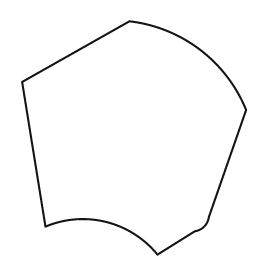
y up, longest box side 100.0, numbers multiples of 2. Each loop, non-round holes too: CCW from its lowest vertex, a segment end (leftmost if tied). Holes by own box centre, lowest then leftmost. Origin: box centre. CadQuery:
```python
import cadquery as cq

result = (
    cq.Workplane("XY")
    .moveTo(10.0, -50.0)
    .lineTo(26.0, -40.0)
    .threePointArc((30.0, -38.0), (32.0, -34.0))
    .lineTo(48.0, 12.0)
    .threePointArc((28.0, 38.0), (-2.0, 50.0))
    .lineTo(-48.0, 24.0)
    .lineTo(-38.0, -38.0)
    .threePointArc((-12.0, -36.0), (10.0, -50.0))
    .close()
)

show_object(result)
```